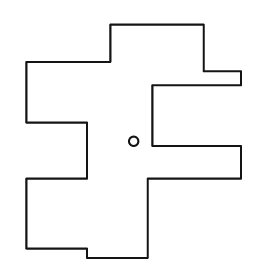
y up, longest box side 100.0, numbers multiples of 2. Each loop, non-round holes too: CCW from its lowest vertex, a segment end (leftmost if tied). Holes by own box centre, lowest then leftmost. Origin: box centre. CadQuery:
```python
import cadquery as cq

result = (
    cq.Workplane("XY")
    .moveTo(-20.0, -50.0)
    .lineTo(6.0, -50.0)
    .lineTo(6.0, -16.0)
    .lineTo(46.0, -16.0)
    .lineTo(46.0, -2.0)
    .lineTo(8.0, -2.0)
    .lineTo(8.0, 24.0)
    .lineTo(46.0, 24.0)
    .lineTo(46.0, 30.0)
    .lineTo(30.0, 30.0)
    .lineTo(30.0, 50.0)
    .lineTo(-10.0, 50.0)
    .lineTo(-10.0, 34.0)
    .lineTo(-46.0, 34.0)
    .lineTo(-46.0, 8.0)
    .lineTo(-20.0, 8.0)
    .lineTo(-20.0, -16.0)
    .lineTo(-46.0, -16.0)
    .lineTo(-46.0, -46.0)
    .lineTo(-20.0, -46.0)
    .close()
    .moveTo(0.0, 0.0)
    .circle(2.0)
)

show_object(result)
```